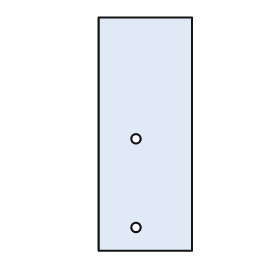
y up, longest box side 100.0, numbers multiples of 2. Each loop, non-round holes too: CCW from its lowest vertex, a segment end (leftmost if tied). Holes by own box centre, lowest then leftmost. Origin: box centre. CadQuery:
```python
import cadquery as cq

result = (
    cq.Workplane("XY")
    .moveTo(-20.0, -50.0)
    .lineTo(20.0, -50.0)
    .lineTo(20.0, 50.0)
    .lineTo(-20.0, 50.0)
    .close()
    .moveTo(-4.0, -40.0)
    .circle(2.0)
    .moveTo(-4.0, -2.0)
    .circle(2.0)
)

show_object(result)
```